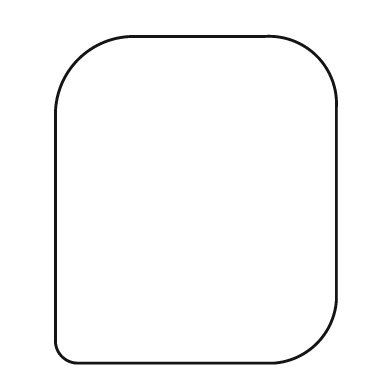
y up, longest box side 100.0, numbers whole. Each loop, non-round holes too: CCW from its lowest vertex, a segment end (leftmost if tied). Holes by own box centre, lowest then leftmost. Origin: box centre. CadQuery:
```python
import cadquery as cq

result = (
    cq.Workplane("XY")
    .moveTo(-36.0, -50.0)
    .lineTo(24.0, -50.0)
    .threePointArc((37.0, -44.0), (43.0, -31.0))
    .lineTo(43.0, 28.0)
    .threePointArc((37.0, 44.0), (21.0, 50.0))
    .lineTo(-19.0, 50.0)
    .threePointArc((-36.0, 43.0), (-43.0, 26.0))
    .lineTo(-43.0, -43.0)
    .threePointArc((-41.0, -48.0), (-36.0, -50.0))
    .close()
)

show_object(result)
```